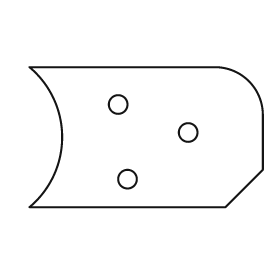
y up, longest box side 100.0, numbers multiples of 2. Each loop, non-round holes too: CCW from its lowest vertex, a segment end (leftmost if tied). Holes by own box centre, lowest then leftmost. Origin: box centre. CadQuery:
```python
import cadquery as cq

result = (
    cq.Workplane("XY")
    .moveTo(-50.0, -30.0)
    .lineTo(34.0, -30.0)
    .lineTo(50.0, -14.0)
    .lineTo(50.0, 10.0)
    .threePointArc((44.0, 24.0), (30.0, 30.0))
    .lineTo(-50.0, 30.0)
    .threePointArc((-36.0, 0.0), (-50.0, -30.0))
    .close()
    .moveTo(-8.0, -18.0)
    .circle(4.0)
    .moveTo(18.0, 2.0)
    .circle(4.0)
    .moveTo(-12.0, 14.0)
    .circle(4.0)
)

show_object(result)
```